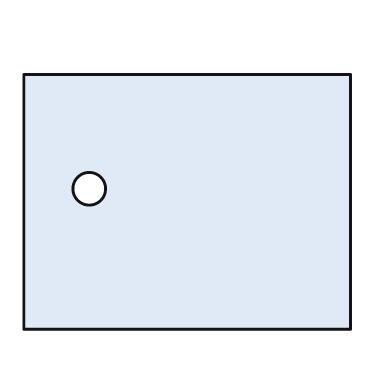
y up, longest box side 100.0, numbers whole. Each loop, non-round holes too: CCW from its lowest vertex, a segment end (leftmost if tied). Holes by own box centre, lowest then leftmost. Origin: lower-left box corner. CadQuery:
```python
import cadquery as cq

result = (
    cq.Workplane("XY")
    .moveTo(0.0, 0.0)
    .lineTo(100.0, 0.0)
    .lineTo(100.0, 78.0)
    .lineTo(0.0, 78.0)
    .close()
    .moveTo(20.0, 43.0)
    .circle(5.0)
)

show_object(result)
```